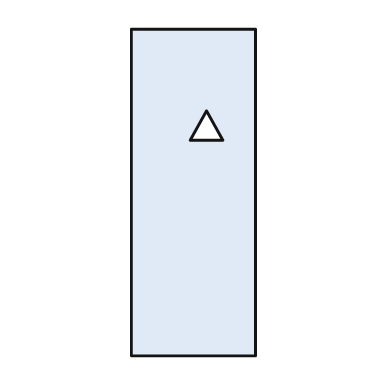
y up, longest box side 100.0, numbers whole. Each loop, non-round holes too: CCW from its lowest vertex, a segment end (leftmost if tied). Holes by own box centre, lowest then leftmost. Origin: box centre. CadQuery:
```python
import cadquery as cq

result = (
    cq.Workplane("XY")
    .moveTo(-19.0, -50.0)
    .lineTo(19.0, -50.0)
    .lineTo(19.0, 50.0)
    .lineTo(-19.0, 50.0)
    .close()
    .moveTo(-1.0, 16.0)
    .lineTo(9.0, 16.0)
    .lineTo(4.0, 25.0)
    .close()
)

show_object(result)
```